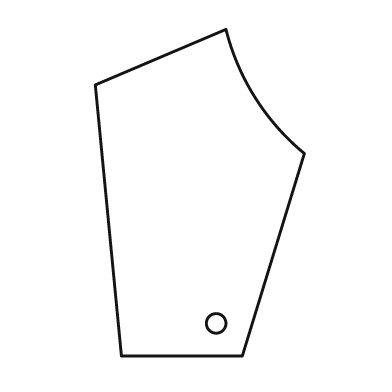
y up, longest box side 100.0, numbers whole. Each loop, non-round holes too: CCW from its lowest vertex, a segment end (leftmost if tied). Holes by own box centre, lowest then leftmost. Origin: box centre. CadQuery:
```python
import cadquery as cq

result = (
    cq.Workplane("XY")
    .moveTo(-24.0, -50.0)
    .lineTo(13.0, -50.0)
    .lineTo(32.0, 12.0)
    .threePointArc((17.0, 29.0), (8.0, 50.0))
    .lineTo(-32.0, 33.0)
    .close()
    .moveTo(5.0, -40.0)
    .circle(3.0)
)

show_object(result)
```